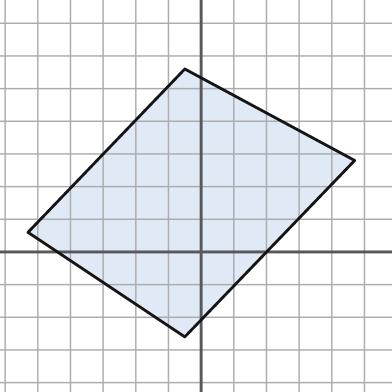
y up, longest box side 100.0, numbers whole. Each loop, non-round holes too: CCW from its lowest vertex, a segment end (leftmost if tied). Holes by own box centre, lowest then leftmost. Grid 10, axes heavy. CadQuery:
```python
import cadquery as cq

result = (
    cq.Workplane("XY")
    .moveTo(-5.0, -26.0)
    .lineTo(47.0, 28.0)
    .lineTo(-5.0, 56.0)
    .lineTo(-53.0, 6.0)
    .close()
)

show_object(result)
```